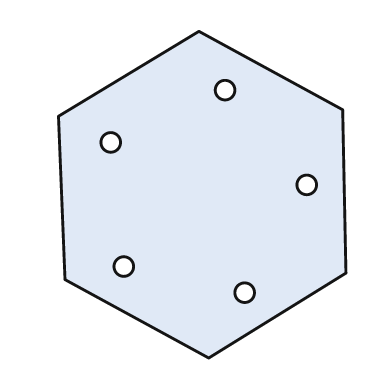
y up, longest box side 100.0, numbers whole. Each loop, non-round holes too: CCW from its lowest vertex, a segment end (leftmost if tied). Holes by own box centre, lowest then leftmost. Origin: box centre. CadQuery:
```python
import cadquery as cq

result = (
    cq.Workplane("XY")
    .moveTo(2.0, -50.0)
    .lineTo(44.0, -24.0)
    .lineTo(43.0, 26.0)
    .lineTo(-1.0, 50.0)
    .lineTo(-44.0, 24.0)
    .lineTo(-42.0, -26.0)
    .close()
    .moveTo(13.0, -30.0)
    .circle(3.0)
    .moveTo(-24.0, -22.0)
    .circle(3.0)
    .moveTo(32.0, 3.0)
    .circle(3.0)
    .moveTo(-28.0, 16.0)
    .circle(3.0)
    .moveTo(7.0, 32.0)
    .circle(3.0)
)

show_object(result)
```